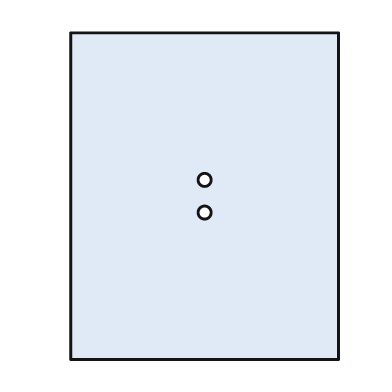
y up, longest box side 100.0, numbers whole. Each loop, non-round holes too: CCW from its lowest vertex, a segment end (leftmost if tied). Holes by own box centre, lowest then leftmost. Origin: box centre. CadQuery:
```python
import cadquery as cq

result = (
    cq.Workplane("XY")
    .moveTo(-41.0, -50.0)
    .lineTo(41.0, -50.0)
    .lineTo(41.0, 50.0)
    .lineTo(-41.0, 50.0)
    .close()
    .moveTo(0.0, -5.0)
    .circle(2.0)
    .moveTo(0.0, 5.0)
    .circle(2.0)
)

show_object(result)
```